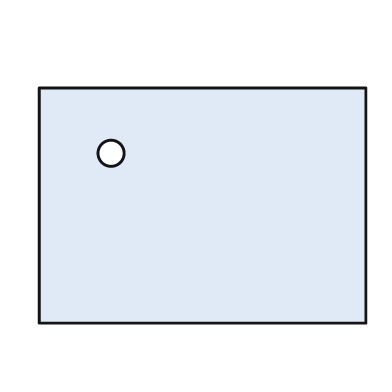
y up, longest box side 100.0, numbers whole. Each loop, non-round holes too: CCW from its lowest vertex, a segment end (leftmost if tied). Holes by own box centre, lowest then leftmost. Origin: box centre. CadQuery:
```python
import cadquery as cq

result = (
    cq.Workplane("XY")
    .moveTo(-50.0, -36.0)
    .lineTo(50.0, -36.0)
    .lineTo(50.0, 36.0)
    .lineTo(-50.0, 36.0)
    .close()
    .moveTo(-28.0, 16.0)
    .circle(4.0)
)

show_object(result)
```